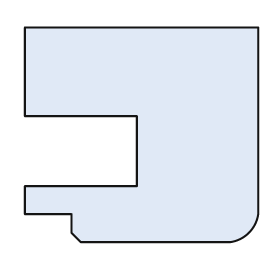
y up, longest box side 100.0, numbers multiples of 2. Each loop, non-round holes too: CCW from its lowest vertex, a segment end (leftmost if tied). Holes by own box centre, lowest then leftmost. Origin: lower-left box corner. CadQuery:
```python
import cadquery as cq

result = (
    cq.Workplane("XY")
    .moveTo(24.0, 0.0)
    .lineTo(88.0, 0.0)
    .threePointArc((96.0, 4.0), (100.0, 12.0))
    .lineTo(100.0, 92.0)
    .lineTo(0.0, 92.0)
    .lineTo(0.0, 54.0)
    .lineTo(48.0, 54.0)
    .lineTo(48.0, 24.0)
    .lineTo(0.0, 24.0)
    .lineTo(0.0, 12.0)
    .lineTo(20.0, 12.0)
    .lineTo(20.0, 4.0)
    .close()
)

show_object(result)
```